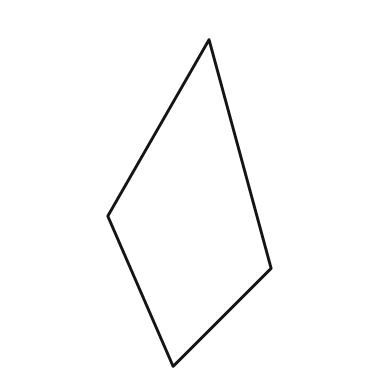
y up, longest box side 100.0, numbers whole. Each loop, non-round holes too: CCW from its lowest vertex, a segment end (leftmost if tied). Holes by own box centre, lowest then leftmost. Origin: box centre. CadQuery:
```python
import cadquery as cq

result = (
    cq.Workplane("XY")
    .moveTo(-5.0, -50.0)
    .lineTo(25.0, -20.0)
    .lineTo(6.0, 50.0)
    .lineTo(-25.0, -4.0)
    .close()
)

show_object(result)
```